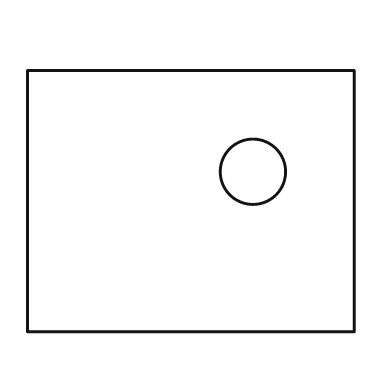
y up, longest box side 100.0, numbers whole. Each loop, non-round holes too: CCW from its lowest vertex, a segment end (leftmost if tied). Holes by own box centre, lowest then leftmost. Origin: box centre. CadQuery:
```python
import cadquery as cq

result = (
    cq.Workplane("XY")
    .moveTo(-50.0, -40.0)
    .lineTo(50.0, -40.0)
    .lineTo(50.0, 40.0)
    .lineTo(-50.0, 40.0)
    .close()
    .moveTo(19.0, 9.0)
    .circle(10.0)
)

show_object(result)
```